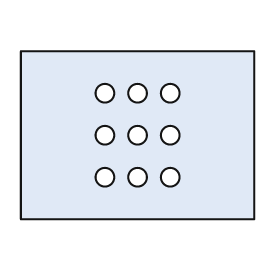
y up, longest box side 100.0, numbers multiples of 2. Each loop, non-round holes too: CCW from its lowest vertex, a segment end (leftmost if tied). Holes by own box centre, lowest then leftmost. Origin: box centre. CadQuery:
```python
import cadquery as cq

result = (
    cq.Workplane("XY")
    .moveTo(-50.0, -36.0)
    .lineTo(50.0, -36.0)
    .lineTo(50.0, 36.0)
    .lineTo(-50.0, 36.0)
    .close()
    .moveTo(-14.0, -18.0)
    .circle(4.0)
    .moveTo(0.0, -18.0)
    .circle(4.0)
    .moveTo(14.0, -18.0)
    .circle(4.0)
    .moveTo(-14.0, 0.0)
    .circle(4.0)
    .moveTo(0.0, 0.0)
    .circle(4.0)
    .moveTo(14.0, 0.0)
    .circle(4.0)
    .moveTo(-14.0, 18.0)
    .circle(4.0)
    .moveTo(0.0, 18.0)
    .circle(4.0)
    .moveTo(14.0, 18.0)
    .circle(4.0)
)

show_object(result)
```